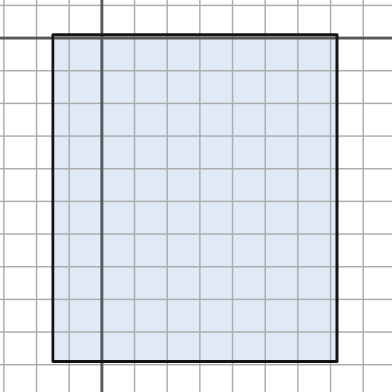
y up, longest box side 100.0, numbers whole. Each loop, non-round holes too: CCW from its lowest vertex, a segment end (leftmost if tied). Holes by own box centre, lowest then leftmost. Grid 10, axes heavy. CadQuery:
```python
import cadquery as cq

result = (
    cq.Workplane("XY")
    .moveTo(-15.0, -99.0)
    .lineTo(72.0, -99.0)
    .lineTo(72.0, 1.0)
    .lineTo(-15.0, 1.0)
    .close()
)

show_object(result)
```